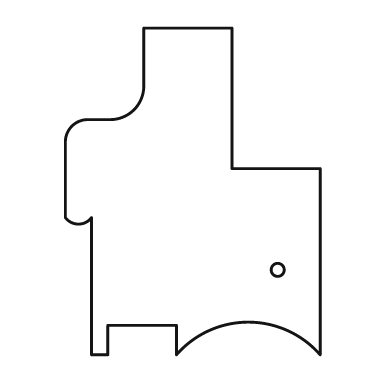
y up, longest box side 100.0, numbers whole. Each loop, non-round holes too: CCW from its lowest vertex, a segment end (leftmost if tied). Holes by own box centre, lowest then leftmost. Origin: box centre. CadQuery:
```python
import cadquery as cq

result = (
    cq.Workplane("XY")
    .moveTo(-31.0, -50.0)
    .lineTo(-26.0, -50.0)
    .lineTo(-26.0, -41.0)
    .lineTo(-5.0, -41.0)
    .lineTo(-5.0, -50.0)
    .threePointArc((17.0, -40.0), (39.0, -50.0))
    .lineTo(39.0, 7.0)
    .lineTo(12.0, 7.0)
    .lineTo(12.0, 50.0)
    .lineTo(-15.0, 50.0)
    .lineTo(-15.0, 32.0)
    .threePointArc((-18.0, 25.0), (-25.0, 22.0))
    .lineTo(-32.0, 22.0)
    .threePointArc((-37.0, 20.0), (-39.0, 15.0))
    .lineTo(-39.0, -8.0)
    .threePointArc((-35.0, -10.0), (-31.0, -8.0))
    .close()
    .moveTo(26.0, -24.0)
    .circle(2.0)
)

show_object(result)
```